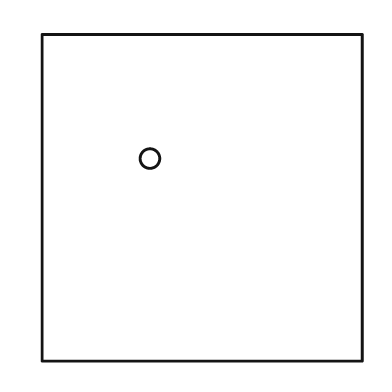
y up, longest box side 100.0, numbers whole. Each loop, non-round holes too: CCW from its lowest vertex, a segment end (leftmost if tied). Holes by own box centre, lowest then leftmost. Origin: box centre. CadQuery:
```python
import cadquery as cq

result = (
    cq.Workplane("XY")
    .moveTo(-49.0, -50.0)
    .lineTo(49.0, -50.0)
    .lineTo(49.0, 50.0)
    .lineTo(-49.0, 50.0)
    .close()
    .moveTo(-16.0, 12.0)
    .circle(3.0)
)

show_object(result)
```